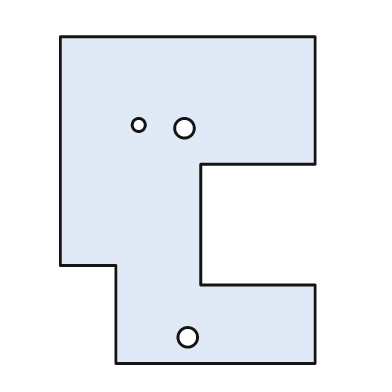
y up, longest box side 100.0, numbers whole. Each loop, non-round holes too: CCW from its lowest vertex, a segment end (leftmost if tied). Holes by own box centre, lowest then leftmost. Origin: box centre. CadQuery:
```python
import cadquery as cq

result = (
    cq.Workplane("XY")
    .moveTo(-22.0, -50.0)
    .lineTo(39.0, -50.0)
    .lineTo(39.0, -26.0)
    .lineTo(4.0, -26.0)
    .lineTo(4.0, 11.0)
    .lineTo(39.0, 11.0)
    .lineTo(39.0, 50.0)
    .lineTo(-39.0, 50.0)
    .lineTo(-39.0, -20.0)
    .lineTo(-22.0, -20.0)
    .close()
    .moveTo(0.0, -42.0)
    .circle(3.0)
    .moveTo(-1.0, 22.0)
    .circle(3.0)
    .moveTo(-15.0, 23.0)
    .circle(2.0)
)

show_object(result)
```